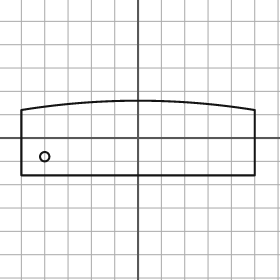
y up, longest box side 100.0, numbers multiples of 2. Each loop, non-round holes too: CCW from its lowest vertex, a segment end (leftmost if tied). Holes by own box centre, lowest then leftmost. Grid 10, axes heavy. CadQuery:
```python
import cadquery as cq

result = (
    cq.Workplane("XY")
    .moveTo(-50.0, -16.0)
    .lineTo(50.0, -16.0)
    .lineTo(50.0, 12.0)
    .threePointArc((0.0, 16.0), (-50.0, 12.0))
    .close()
    .moveTo(-40.0, -8.0)
    .circle(2.0)
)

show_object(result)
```